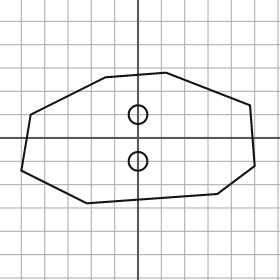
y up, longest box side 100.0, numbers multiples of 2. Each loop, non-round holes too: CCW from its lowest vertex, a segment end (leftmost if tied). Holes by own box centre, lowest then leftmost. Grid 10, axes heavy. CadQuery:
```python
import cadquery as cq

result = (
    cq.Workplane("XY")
    .moveTo(-22.0, -28.0)
    .lineTo(34.0, -24.0)
    .lineTo(50.0, -12.0)
    .lineTo(48.0, 14.0)
    .lineTo(12.0, 28.0)
    .lineTo(-14.0, 26.0)
    .lineTo(-46.0, 10.0)
    .lineTo(-50.0, -14.0)
    .close()
    .moveTo(0.0, -10.0)
    .circle(4.0)
    .moveTo(0.0, 10.0)
    .circle(4.0)
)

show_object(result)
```